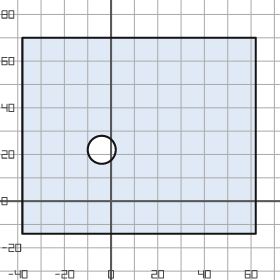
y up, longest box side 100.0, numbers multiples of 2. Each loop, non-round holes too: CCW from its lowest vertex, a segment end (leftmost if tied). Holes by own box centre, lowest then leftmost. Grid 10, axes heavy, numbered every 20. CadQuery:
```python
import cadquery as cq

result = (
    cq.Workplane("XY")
    .moveTo(-38.0, -14.0)
    .lineTo(62.0, -14.0)
    .lineTo(62.0, 70.0)
    .lineTo(-38.0, 70.0)
    .close()
    .moveTo(-4.0, 22.0)
    .circle(6.0)
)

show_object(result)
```